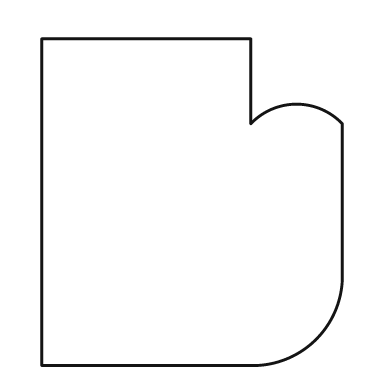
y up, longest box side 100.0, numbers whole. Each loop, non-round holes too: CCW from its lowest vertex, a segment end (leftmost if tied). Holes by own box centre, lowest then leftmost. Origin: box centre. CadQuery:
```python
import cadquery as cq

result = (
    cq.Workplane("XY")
    .moveTo(-46.0, -50.0)
    .lineTo(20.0, -50.0)
    .threePointArc((38.0, -42.0), (46.0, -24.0))
    .lineTo(46.0, 24.0)
    .threePointArc((32.0, 30.0), (18.0, 24.0))
    .lineTo(18.0, 50.0)
    .lineTo(-46.0, 50.0)
    .close()
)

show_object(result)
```